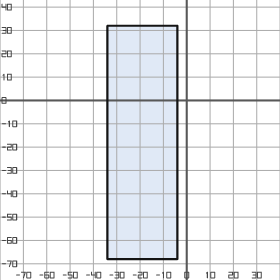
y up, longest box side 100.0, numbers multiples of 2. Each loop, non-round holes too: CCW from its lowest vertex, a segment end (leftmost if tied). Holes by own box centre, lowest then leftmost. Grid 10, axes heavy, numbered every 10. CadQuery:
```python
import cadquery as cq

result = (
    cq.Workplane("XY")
    .moveTo(-34.0, -68.0)
    .lineTo(-4.0, -68.0)
    .lineTo(-4.0, 32.0)
    .lineTo(-34.0, 32.0)
    .close()
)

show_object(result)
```